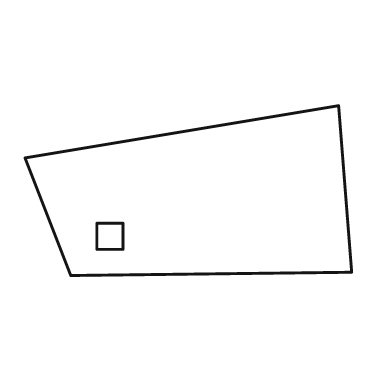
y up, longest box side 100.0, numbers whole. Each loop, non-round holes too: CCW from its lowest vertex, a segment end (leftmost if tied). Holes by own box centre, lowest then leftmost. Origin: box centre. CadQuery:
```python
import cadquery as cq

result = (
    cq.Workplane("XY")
    .moveTo(-36.0, -26.0)
    .lineTo(50.0, -25.0)
    .lineTo(46.0, 26.0)
    .lineTo(-50.0, 10.0)
    .close()
    .moveTo(-28.0, -18.0)
    .lineTo(-20.0, -18.0)
    .lineTo(-20.0, -10.0)
    .lineTo(-28.0, -10.0)
    .close()
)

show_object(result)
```